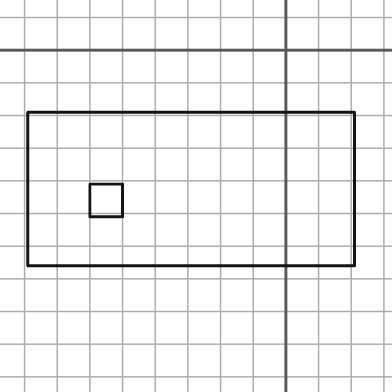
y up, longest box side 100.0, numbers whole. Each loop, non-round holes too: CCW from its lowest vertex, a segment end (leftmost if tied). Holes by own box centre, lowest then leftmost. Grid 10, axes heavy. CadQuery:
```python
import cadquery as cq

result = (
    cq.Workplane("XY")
    .moveTo(-79.0, -66.0)
    .lineTo(21.0, -66.0)
    .lineTo(21.0, -19.0)
    .lineTo(-79.0, -19.0)
    .close()
    .moveTo(-60.0, -51.0)
    .lineTo(-50.0, -51.0)
    .lineTo(-50.0, -41.0)
    .lineTo(-60.0, -41.0)
    .close()
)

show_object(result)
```